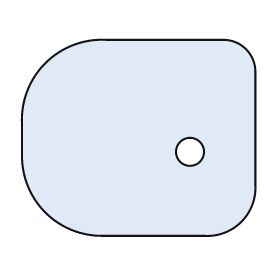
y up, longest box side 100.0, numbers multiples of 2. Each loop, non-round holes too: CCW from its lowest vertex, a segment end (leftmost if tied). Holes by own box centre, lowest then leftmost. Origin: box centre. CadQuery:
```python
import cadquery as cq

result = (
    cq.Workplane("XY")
    .moveTo(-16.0, -42.0)
    .lineTo(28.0, -42.0)
    .threePointArc((44.0, -36.0), (50.0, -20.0))
    .lineTo(50.0, 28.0)
    .threePointArc((46.0, 38.0), (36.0, 42.0))
    .lineTo(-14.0, 42.0)
    .threePointArc((-40.0, 32.0), (-50.0, 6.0))
    .lineTo(-50.0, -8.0)
    .threePointArc((-40.0, -32.0), (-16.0, -42.0))
    .close()
    .moveTo(22.0, -6.0)
    .circle(6.0)
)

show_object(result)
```